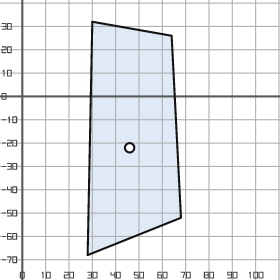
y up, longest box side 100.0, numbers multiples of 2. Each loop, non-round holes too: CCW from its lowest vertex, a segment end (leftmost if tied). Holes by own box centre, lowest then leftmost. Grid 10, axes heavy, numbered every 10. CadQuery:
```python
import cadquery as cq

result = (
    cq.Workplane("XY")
    .moveTo(28.0, -68.0)
    .lineTo(68.0, -52.0)
    .lineTo(64.0, 26.0)
    .lineTo(30.0, 32.0)
    .close()
    .moveTo(46.0, -22.0)
    .circle(2.0)
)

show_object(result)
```